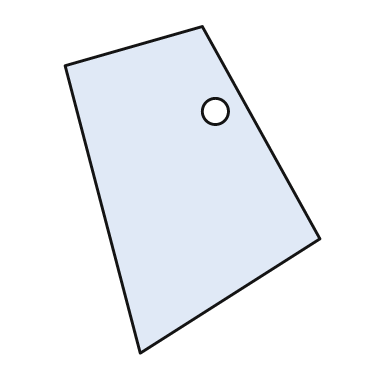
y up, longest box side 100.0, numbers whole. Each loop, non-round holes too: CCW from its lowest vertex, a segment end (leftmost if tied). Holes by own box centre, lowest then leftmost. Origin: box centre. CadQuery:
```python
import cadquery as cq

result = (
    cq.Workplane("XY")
    .moveTo(-16.0, -50.0)
    .lineTo(39.0, -15.0)
    .lineTo(3.0, 50.0)
    .lineTo(-39.0, 38.0)
    .close()
    .moveTo(7.0, 24.0)
    .circle(4.0)
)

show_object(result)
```